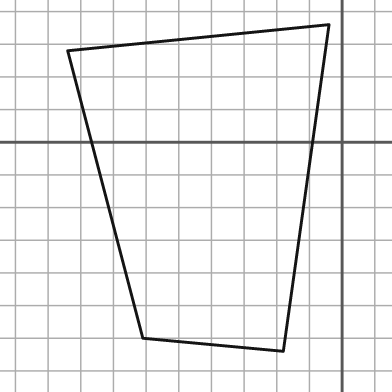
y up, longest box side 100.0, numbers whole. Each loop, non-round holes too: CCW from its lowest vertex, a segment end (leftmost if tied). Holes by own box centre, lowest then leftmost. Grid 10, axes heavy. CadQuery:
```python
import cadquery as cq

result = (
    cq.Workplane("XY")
    .moveTo(-18.0, -64.0)
    .lineTo(-4.0, 36.0)
    .lineTo(-84.0, 28.0)
    .lineTo(-61.0, -60.0)
    .close()
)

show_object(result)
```